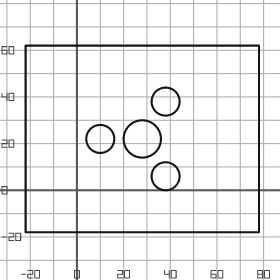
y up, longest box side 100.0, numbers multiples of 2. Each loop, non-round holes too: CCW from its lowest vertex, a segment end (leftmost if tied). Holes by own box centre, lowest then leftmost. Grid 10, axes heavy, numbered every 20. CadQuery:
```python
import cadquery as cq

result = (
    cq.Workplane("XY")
    .moveTo(-22.0, -18.0)
    .lineTo(78.0, -18.0)
    .lineTo(78.0, 62.0)
    .lineTo(-22.0, 62.0)
    .close()
    .moveTo(38.0, 6.0)
    .circle(6.0)
    .moveTo(10.0, 22.0)
    .circle(6.0)
    .moveTo(28.0, 22.0)
    .circle(8.0)
    .moveTo(38.0, 38.0)
    .circle(6.0)
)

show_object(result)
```